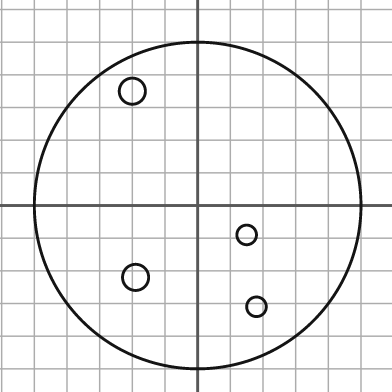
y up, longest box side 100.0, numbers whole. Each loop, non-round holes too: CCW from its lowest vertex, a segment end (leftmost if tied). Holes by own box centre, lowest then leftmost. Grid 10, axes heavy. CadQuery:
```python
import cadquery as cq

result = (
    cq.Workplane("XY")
    .moveTo(0.0, 0.0)
    .circle(50.0)
    .moveTo(18.0, -31.0)
    .circle(3.0)
    .moveTo(-19.0, -22.0)
    .circle(4.0)
    .moveTo(15.0, -9.0)
    .circle(3.0)
    .moveTo(-20.0, 35.0)
    .circle(4.0)
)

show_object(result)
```